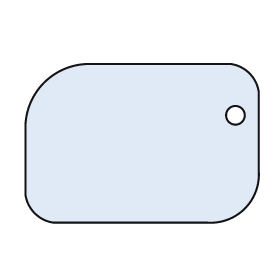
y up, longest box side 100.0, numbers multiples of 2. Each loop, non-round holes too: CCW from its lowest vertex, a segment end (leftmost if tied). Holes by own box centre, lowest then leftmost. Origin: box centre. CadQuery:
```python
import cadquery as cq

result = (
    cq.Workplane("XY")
    .moveTo(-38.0, -34.0)
    .lineTo(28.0, -34.0)
    .threePointArc((44.0, -28.0), (50.0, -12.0))
    .lineTo(50.0, 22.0)
    .threePointArc((46.0, 30.0), (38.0, 34.0))
    .lineTo(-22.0, 34.0)
    .threePointArc((-42.0, 26.0), (-50.0, 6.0))
    .lineTo(-50.0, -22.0)
    .threePointArc((-46.0, -30.0), (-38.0, -34.0))
    .close()
    .moveTo(40.0, 12.0)
    .circle(4.0)
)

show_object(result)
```